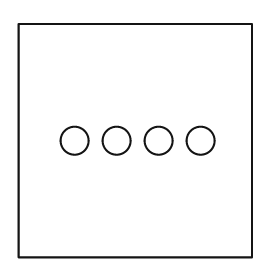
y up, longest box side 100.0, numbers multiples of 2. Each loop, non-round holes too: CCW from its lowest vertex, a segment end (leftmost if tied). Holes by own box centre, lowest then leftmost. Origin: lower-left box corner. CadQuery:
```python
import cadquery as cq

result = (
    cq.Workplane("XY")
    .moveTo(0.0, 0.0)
    .lineTo(100.0, 0.0)
    .lineTo(100.0, 100.0)
    .lineTo(0.0, 100.0)
    .close()
    .moveTo(24.0, 50.0)
    .circle(6.0)
    .moveTo(42.0, 50.0)
    .circle(6.0)
    .moveTo(60.0, 50.0)
    .circle(6.0)
    .moveTo(78.0, 50.0)
    .circle(6.0)
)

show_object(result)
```